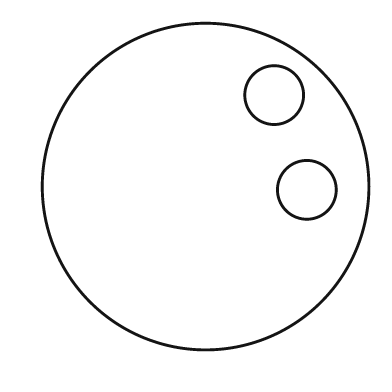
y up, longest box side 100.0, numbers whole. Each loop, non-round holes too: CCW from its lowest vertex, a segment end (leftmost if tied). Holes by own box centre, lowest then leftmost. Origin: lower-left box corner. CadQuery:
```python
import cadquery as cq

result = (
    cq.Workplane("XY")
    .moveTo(50.0, 50.0)
    .circle(50.0)
    .moveTo(81.0, 49.0)
    .circle(9.0)
    .moveTo(71.0, 78.0)
    .circle(9.0)
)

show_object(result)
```